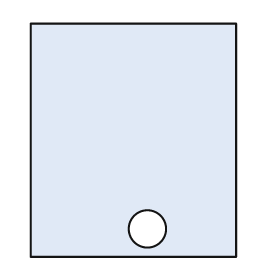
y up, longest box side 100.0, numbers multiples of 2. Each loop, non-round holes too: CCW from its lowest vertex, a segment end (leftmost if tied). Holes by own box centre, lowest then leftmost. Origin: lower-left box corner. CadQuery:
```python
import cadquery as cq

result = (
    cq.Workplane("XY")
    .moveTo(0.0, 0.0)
    .lineTo(88.0, 0.0)
    .lineTo(88.0, 100.0)
    .lineTo(0.0, 100.0)
    .close()
    .moveTo(50.0, 12.0)
    .circle(8.0)
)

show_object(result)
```